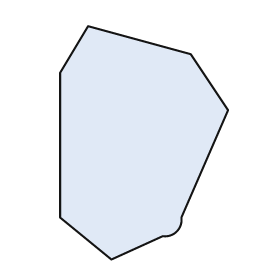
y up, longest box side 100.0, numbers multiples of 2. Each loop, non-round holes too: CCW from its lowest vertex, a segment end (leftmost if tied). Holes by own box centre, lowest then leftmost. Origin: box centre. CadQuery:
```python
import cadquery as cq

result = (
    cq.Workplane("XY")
    .moveTo(-14.0, -50.0)
    .lineTo(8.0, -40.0)
    .threePointArc((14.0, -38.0), (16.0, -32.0))
    .lineTo(36.0, 14.0)
    .lineTo(20.0, 38.0)
    .lineTo(-24.0, 50.0)
    .lineTo(-36.0, 30.0)
    .lineTo(-36.0, -32.0)
    .close()
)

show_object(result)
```